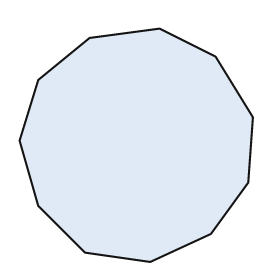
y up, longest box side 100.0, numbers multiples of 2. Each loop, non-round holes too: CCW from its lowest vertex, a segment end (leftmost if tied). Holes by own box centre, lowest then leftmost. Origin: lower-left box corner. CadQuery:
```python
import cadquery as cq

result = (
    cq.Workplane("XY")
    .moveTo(56.0, 0.0)
    .lineTo(82.0, 12.0)
    .lineTo(98.0, 34.0)
    .lineTo(100.0, 62.0)
    .lineTo(84.0, 88.0)
    .lineTo(60.0, 100.0)
    .lineTo(30.0, 96.0)
    .lineTo(8.0, 78.0)
    .lineTo(0.0, 52.0)
    .lineTo(8.0, 24.0)
    .lineTo(28.0, 4.0)
    .close()
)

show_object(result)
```